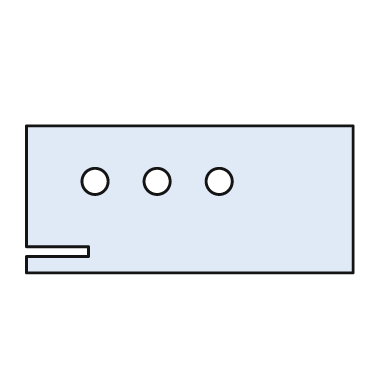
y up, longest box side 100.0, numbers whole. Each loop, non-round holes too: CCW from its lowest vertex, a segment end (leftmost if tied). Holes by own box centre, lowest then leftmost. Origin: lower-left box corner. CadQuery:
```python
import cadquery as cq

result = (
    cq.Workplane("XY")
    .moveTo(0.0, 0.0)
    .lineTo(100.0, 0.0)
    .lineTo(100.0, 45.0)
    .lineTo(0.0, 45.0)
    .lineTo(0.0, 8.0)
    .lineTo(19.0, 8.0)
    .lineTo(19.0, 5.0)
    .lineTo(0.0, 5.0)
    .close()
    .moveTo(21.0, 28.0)
    .circle(4.0)
    .moveTo(40.0, 28.0)
    .circle(4.0)
    .moveTo(59.0, 28.0)
    .circle(4.0)
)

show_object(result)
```